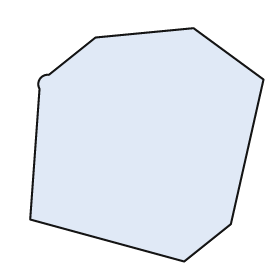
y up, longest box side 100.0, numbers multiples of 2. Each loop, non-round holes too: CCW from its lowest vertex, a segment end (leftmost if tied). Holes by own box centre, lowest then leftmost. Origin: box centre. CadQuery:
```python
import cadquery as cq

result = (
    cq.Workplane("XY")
    .moveTo(16.0, -50.0)
    .lineTo(36.0, -34.0)
    .lineTo(50.0, 28.0)
    .lineTo(20.0, 50.0)
    .lineTo(-22.0, 46.0)
    .lineTo(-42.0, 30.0)
    .threePointArc((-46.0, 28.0), (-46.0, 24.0))
    .lineTo(-50.0, -32.0)
    .close()
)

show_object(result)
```